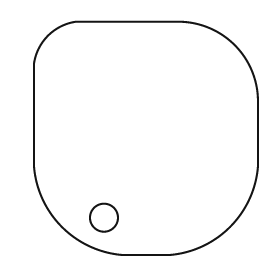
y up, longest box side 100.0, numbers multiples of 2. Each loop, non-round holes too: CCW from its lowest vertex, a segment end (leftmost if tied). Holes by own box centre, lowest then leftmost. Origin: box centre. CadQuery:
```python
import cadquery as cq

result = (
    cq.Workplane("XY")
    .moveTo(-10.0, -50.0)
    .lineTo(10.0, -50.0)
    .threePointArc((36.0, -38.0), (48.0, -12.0))
    .lineTo(48.0, 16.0)
    .threePointArc((38.0, 40.0), (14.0, 50.0))
    .lineTo(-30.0, 50.0)
    .threePointArc((-42.0, 44.0), (-48.0, 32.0))
    .lineTo(-48.0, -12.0)
    .threePointArc((-36.0, -38.0), (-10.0, -50.0))
    .close()
    .moveTo(-18.0, -34.0)
    .circle(6.0)
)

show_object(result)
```